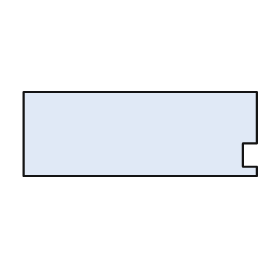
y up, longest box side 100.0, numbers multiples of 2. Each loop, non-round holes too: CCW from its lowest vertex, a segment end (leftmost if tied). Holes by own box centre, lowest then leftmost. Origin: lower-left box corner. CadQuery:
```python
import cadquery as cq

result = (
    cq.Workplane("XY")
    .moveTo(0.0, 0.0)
    .lineTo(100.0, 0.0)
    .lineTo(100.0, 4.0)
    .lineTo(94.0, 4.0)
    .lineTo(94.0, 14.0)
    .lineTo(100.0, 14.0)
    .lineTo(100.0, 36.0)
    .lineTo(0.0, 36.0)
    .close()
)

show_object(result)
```